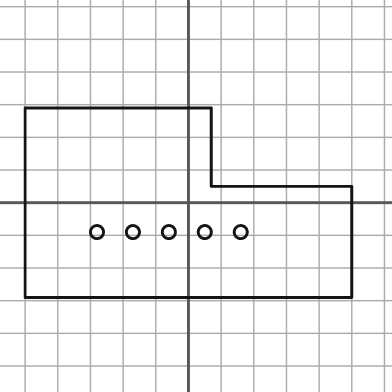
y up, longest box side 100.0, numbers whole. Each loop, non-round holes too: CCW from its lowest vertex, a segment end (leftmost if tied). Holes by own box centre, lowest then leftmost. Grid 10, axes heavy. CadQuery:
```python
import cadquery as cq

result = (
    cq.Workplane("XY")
    .moveTo(-50.0, -29.0)
    .lineTo(50.0, -29.0)
    .lineTo(50.0, 5.0)
    .lineTo(7.0, 5.0)
    .lineTo(7.0, 29.0)
    .lineTo(-50.0, 29.0)
    .close()
    .moveTo(-28.0, -9.0)
    .circle(2.0)
    .moveTo(-17.0, -9.0)
    .circle(2.0)
    .moveTo(-6.0, -9.0)
    .circle(2.0)
    .moveTo(5.0, -9.0)
    .circle(2.0)
    .moveTo(16.0, -9.0)
    .circle(2.0)
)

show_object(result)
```